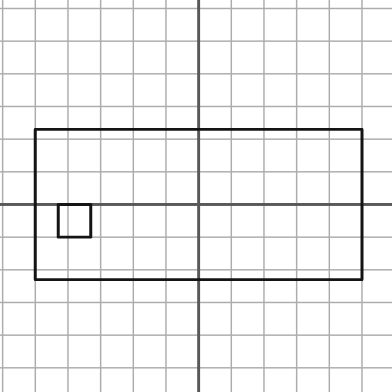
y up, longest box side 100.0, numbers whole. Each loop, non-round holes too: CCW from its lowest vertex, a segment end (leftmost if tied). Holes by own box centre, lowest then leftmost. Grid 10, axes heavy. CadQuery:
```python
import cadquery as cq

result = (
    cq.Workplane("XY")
    .moveTo(-50.0, -23.0)
    .lineTo(50.0, -23.0)
    .lineTo(50.0, 23.0)
    .lineTo(-50.0, 23.0)
    .close()
    .moveTo(-43.0, -10.0)
    .lineTo(-33.0, -10.0)
    .lineTo(-33.0, 0.0)
    .lineTo(-43.0, 0.0)
    .close()
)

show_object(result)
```